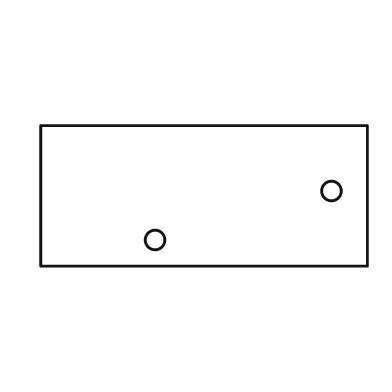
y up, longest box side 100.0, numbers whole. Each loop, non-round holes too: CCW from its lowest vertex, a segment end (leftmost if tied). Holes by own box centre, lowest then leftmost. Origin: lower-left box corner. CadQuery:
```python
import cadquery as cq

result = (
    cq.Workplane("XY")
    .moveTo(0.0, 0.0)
    .lineTo(100.0, 0.0)
    .lineTo(100.0, 43.0)
    .lineTo(0.0, 43.0)
    .close()
    .moveTo(35.0, 8.0)
    .circle(3.0)
    .moveTo(89.0, 23.0)
    .circle(3.0)
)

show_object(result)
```